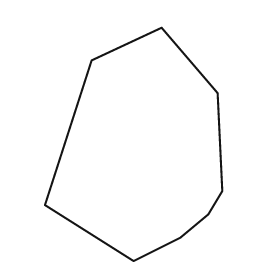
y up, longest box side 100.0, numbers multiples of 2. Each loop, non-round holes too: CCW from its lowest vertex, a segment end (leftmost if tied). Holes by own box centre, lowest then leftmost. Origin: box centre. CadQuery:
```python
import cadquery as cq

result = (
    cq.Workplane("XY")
    .moveTo(0.0, -50.0)
    .lineTo(20.0, -40.0)
    .lineTo(32.0, -30.0)
    .lineTo(38.0, -20.0)
    .lineTo(36.0, 22.0)
    .lineTo(12.0, 50.0)
    .lineTo(-18.0, 36.0)
    .lineTo(-38.0, -26.0)
    .close()
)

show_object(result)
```